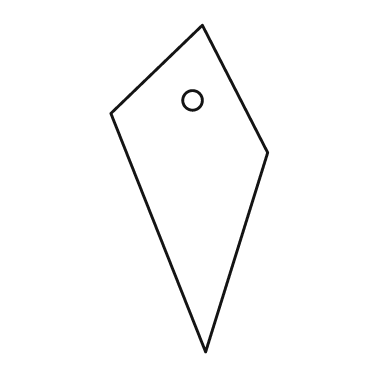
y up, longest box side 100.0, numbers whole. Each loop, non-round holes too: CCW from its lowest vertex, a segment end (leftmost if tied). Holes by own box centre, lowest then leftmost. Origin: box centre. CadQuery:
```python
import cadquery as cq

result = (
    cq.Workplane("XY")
    .moveTo(5.0, -50.0)
    .lineTo(24.0, 11.0)
    .lineTo(4.0, 50.0)
    .lineTo(-24.0, 23.0)
    .close()
    .moveTo(1.0, 27.0)
    .circle(3.0)
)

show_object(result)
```